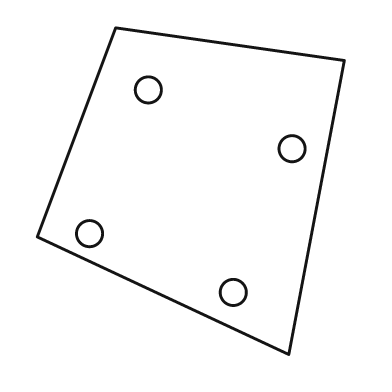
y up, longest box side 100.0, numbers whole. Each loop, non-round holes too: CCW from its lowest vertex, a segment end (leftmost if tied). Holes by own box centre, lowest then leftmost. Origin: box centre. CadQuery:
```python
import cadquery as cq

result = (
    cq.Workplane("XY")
    .moveTo(30.0, -50.0)
    .lineTo(47.0, 40.0)
    .lineTo(-23.0, 50.0)
    .lineTo(-47.0, -14.0)
    .close()
    .moveTo(13.0, -31.0)
    .circle(4.0)
    .moveTo(-31.0, -13.0)
    .circle(4.0)
    .moveTo(31.0, 13.0)
    .circle(4.0)
    .moveTo(-13.0, 31.0)
    .circle(4.0)
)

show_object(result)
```